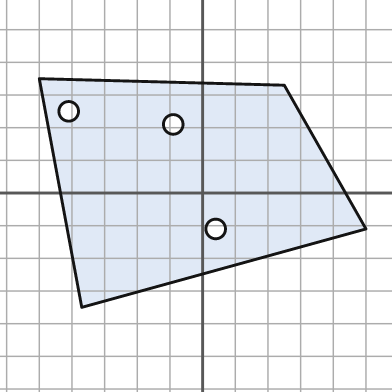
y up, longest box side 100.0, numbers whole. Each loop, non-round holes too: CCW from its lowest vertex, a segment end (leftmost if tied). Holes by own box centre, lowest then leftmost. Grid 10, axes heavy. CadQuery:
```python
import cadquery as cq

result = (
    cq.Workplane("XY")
    .moveTo(-37.0, -35.0)
    .lineTo(50.0, -11.0)
    .lineTo(25.0, 33.0)
    .lineTo(-50.0, 35.0)
    .close()
    .moveTo(4.0, -11.0)
    .circle(3.0)
    .moveTo(-9.0, 21.0)
    .circle(3.0)
    .moveTo(-41.0, 25.0)
    .circle(3.0)
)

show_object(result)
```